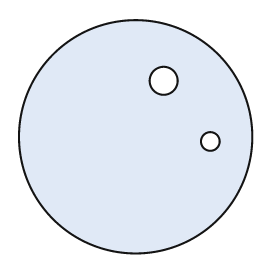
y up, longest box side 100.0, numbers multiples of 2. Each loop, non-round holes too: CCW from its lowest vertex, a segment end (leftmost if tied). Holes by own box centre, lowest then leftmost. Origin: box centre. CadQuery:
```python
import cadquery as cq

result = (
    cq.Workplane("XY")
    .moveTo(0.0, 0.0)
    .circle(50.0)
    .moveTo(32.0, -2.0)
    .circle(4.0)
    .moveTo(12.0, 24.0)
    .circle(6.0)
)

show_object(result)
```